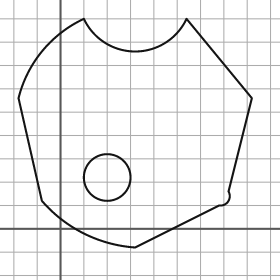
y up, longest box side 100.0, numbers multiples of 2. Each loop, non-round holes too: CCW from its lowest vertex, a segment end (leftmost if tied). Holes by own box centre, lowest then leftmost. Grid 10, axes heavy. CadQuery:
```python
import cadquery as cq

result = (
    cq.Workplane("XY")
    .moveTo(32.0, -8.0)
    .lineTo(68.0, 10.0)
    .threePointArc((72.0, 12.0), (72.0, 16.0))
    .lineTo(82.0, 56.0)
    .lineTo(54.0, 90.0)
    .threePointArc((32.0, 76.0), (10.0, 90.0))
    .threePointArc((-8.0, 76.0), (-18.0, 56.0))
    .lineTo(-8.0, 12.0)
    .threePointArc((10.0, -2.0), (32.0, -8.0))
    .close()
    .moveTo(20.0, 22.0)
    .circle(10.0)
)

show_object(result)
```